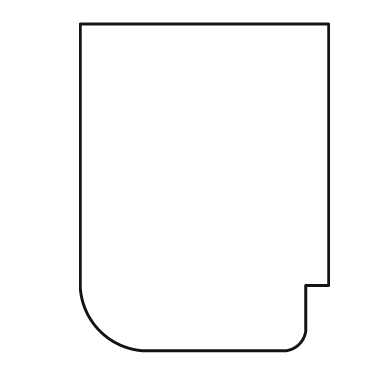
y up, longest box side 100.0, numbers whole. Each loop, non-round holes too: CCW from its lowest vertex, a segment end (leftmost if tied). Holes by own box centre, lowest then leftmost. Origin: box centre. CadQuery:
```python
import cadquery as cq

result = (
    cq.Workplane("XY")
    .moveTo(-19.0, -50.0)
    .lineTo(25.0, -50.0)
    .threePointArc((29.0, -48.0), (31.0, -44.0))
    .lineTo(31.0, -30.0)
    .lineTo(38.0, -30.0)
    .lineTo(38.0, 50.0)
    .lineTo(-38.0, 50.0)
    .lineTo(-38.0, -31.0)
    .threePointArc((-32.0, -44.0), (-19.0, -50.0))
    .close()
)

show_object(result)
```